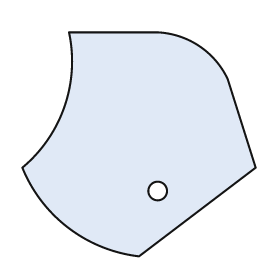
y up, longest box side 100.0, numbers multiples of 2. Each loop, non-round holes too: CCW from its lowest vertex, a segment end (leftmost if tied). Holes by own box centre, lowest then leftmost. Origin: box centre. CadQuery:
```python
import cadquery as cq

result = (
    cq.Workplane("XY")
    .moveTo(0.0, -48.0)
    .lineTo(50.0, -10.0)
    .lineTo(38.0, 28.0)
    .threePointArc((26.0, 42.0), (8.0, 48.0))
    .lineTo(-30.0, 48.0)
    .threePointArc((-32.0, 16.0), (-50.0, -10.0))
    .threePointArc((-30.0, -36.0), (0.0, -48.0))
    .close()
    .moveTo(8.0, -20.0)
    .circle(4.0)
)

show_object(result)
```